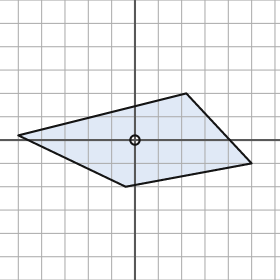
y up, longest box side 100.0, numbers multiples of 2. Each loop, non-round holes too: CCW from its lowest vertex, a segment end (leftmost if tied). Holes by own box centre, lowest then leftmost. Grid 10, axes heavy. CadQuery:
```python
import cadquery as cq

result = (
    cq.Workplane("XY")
    .moveTo(-4.0, -20.0)
    .lineTo(50.0, -10.0)
    .lineTo(22.0, 20.0)
    .lineTo(-50.0, 2.0)
    .close()
    .moveTo(0.0, 0.0)
    .circle(2.0)
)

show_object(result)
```